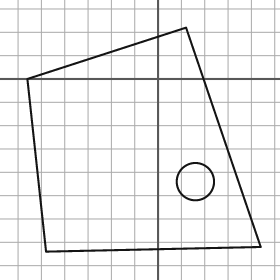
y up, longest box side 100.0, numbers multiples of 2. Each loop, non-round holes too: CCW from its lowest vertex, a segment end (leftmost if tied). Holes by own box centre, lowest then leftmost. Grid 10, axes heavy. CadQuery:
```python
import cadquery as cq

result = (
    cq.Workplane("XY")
    .moveTo(-48.0, -74.0)
    .lineTo(44.0, -72.0)
    .lineTo(12.0, 22.0)
    .lineTo(-56.0, 0.0)
    .close()
    .moveTo(16.0, -44.0)
    .circle(8.0)
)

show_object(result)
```